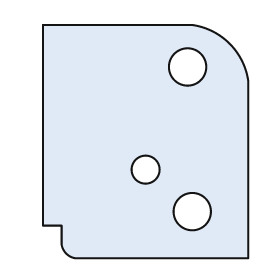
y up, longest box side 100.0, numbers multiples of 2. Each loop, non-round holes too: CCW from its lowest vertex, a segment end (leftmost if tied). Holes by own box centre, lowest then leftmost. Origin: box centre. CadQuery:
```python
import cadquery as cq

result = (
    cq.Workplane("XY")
    .moveTo(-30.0, -50.0)
    .lineTo(44.0, -50.0)
    .lineTo(44.0, 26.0)
    .threePointArc((36.0, 42.0), (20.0, 50.0))
    .lineTo(-44.0, 50.0)
    .lineTo(-44.0, -36.0)
    .lineTo(-36.0, -36.0)
    .lineTo(-36.0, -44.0)
    .threePointArc((-34.0, -48.0), (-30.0, -50.0))
    .close()
    .moveTo(20.0, -30.0)
    .circle(8.0)
    .moveTo(0.0, -12.0)
    .circle(6.0)
    .moveTo(18.0, 32.0)
    .circle(8.0)
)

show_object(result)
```